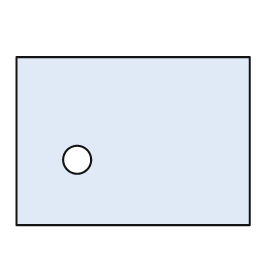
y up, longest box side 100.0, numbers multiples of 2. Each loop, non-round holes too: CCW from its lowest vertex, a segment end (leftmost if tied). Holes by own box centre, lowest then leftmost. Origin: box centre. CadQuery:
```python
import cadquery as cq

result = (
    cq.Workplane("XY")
    .moveTo(-50.0, -36.0)
    .lineTo(50.0, -36.0)
    .lineTo(50.0, 36.0)
    .lineTo(-50.0, 36.0)
    .close()
    .moveTo(-24.0, -8.0)
    .circle(6.0)
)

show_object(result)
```